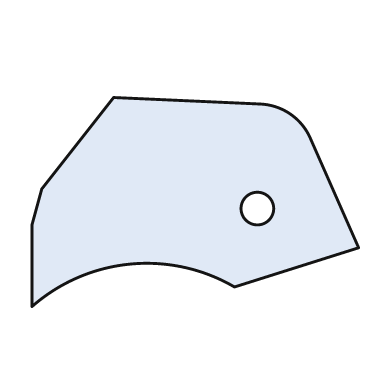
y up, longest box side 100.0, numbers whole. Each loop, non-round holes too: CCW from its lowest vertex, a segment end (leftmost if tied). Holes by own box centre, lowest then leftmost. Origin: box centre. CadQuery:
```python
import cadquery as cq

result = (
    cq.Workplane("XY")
    .moveTo(-50.0, -32.0)
    .threePointArc((-20.0, -19.0), (12.0, -26.0))
    .lineTo(50.0, -14.0)
    .lineTo(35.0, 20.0)
    .threePointArc((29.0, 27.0), (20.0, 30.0))
    .lineTo(-25.0, 32.0)
    .lineTo(-47.0, 4.0)
    .lineTo(-50.0, -7.0)
    .close()
    .moveTo(19.0, -2.0)
    .circle(5.0)
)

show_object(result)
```